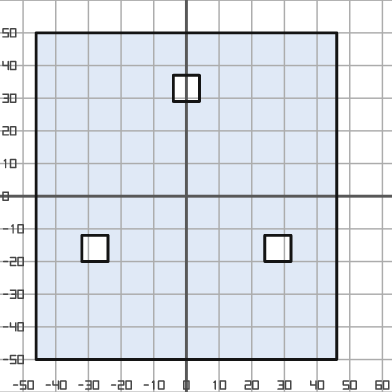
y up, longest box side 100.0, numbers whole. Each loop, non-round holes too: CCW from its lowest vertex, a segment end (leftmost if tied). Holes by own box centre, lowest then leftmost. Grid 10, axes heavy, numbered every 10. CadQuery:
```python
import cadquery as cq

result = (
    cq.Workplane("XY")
    .moveTo(-46.0, -50.0)
    .lineTo(46.0, -50.0)
    .lineTo(46.0, 50.0)
    .lineTo(-46.0, 50.0)
    .close()
    .moveTo(-32.0, -20.0)
    .lineTo(-24.0, -20.0)
    .lineTo(-24.0, -12.0)
    .lineTo(-32.0, -12.0)
    .close()
    .moveTo(24.0, -20.0)
    .lineTo(32.0, -20.0)
    .lineTo(32.0, -12.0)
    .lineTo(24.0, -12.0)
    .close()
    .moveTo(-4.0, 29.0)
    .lineTo(4.0, 29.0)
    .lineTo(4.0, 37.0)
    .lineTo(-4.0, 37.0)
    .close()
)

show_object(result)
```